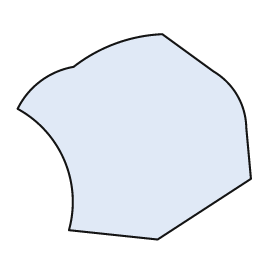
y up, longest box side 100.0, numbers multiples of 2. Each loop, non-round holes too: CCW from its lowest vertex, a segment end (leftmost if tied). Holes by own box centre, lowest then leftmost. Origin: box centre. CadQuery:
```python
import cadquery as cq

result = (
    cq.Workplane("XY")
    .moveTo(10.0, -44.0)
    .lineTo(50.0, -18.0)
    .lineTo(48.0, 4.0)
    .threePointArc((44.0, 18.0), (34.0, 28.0))
    .lineTo(12.0, 44.0)
    .threePointArc((-8.0, 40.0), (-26.0, 30.0))
    .threePointArc((-40.0, 24.0), (-50.0, 12.0))
    .threePointArc((-30.0, -10.0), (-28.0, -40.0))
    .close()
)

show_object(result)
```